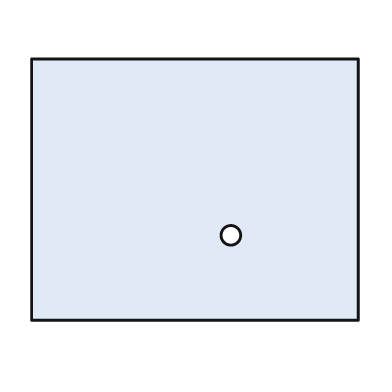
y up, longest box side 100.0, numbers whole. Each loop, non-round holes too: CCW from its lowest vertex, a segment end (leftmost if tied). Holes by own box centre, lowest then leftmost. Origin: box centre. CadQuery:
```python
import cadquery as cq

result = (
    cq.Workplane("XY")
    .moveTo(-50.0, -40.0)
    .lineTo(50.0, -40.0)
    .lineTo(50.0, 40.0)
    .lineTo(-50.0, 40.0)
    .close()
    .moveTo(11.0, -14.0)
    .circle(3.0)
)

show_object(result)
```